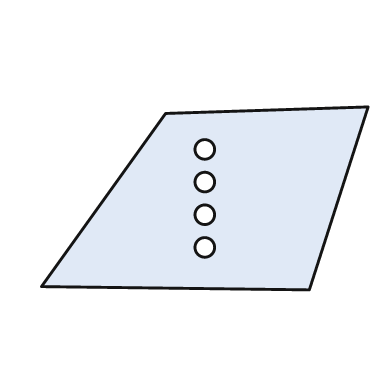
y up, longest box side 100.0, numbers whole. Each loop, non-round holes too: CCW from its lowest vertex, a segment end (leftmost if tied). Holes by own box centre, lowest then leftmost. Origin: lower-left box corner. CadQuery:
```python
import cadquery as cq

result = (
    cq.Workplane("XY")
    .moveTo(82.0, 0.0)
    .lineTo(100.0, 56.0)
    .lineTo(38.0, 54.0)
    .lineTo(0.0, 1.0)
    .close()
    .moveTo(50.0, 13.0)
    .circle(3.0)
    .moveTo(50.0, 23.0)
    .circle(3.0)
    .moveTo(50.0, 33.0)
    .circle(3.0)
    .moveTo(50.0, 43.0)
    .circle(3.0)
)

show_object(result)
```